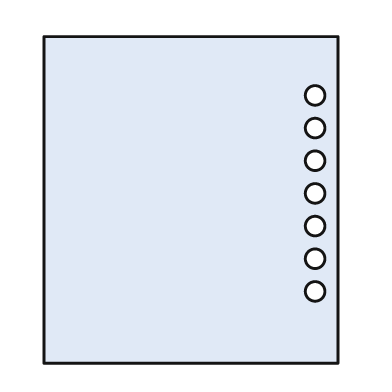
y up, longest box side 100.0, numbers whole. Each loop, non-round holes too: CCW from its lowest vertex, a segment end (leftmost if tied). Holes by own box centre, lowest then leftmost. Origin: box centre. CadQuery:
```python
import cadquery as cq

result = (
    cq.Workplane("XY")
    .moveTo(-45.0, -50.0)
    .lineTo(45.0, -50.0)
    .lineTo(45.0, 50.0)
    .lineTo(-45.0, 50.0)
    .close()
    .moveTo(38.0, -28.0)
    .circle(3.0)
    .moveTo(38.0, -18.0)
    .circle(3.0)
    .moveTo(38.0, -8.0)
    .circle(3.0)
    .moveTo(38.0, 2.0)
    .circle(3.0)
    .moveTo(38.0, 12.0)
    .circle(3.0)
    .moveTo(38.0, 22.0)
    .circle(3.0)
    .moveTo(38.0, 32.0)
    .circle(3.0)
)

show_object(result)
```